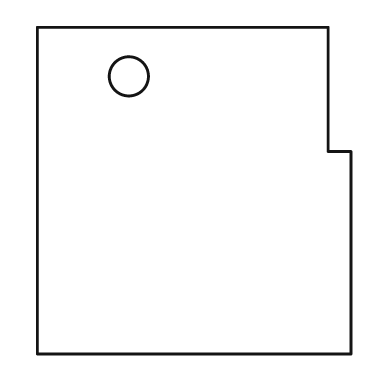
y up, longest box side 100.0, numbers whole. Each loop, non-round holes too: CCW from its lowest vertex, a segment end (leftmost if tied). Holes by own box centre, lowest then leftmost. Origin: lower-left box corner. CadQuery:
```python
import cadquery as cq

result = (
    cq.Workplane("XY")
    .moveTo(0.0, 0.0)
    .lineTo(96.0, 0.0)
    .lineTo(96.0, 62.0)
    .lineTo(89.0, 62.0)
    .lineTo(89.0, 100.0)
    .lineTo(0.0, 100.0)
    .close()
    .moveTo(28.0, 85.0)
    .circle(6.0)
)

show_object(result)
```